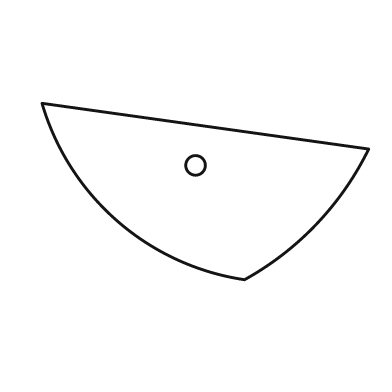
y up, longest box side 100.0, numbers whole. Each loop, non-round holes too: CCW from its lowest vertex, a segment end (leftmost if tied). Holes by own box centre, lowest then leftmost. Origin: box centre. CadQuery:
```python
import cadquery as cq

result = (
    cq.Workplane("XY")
    .moveTo(12.0, -27.0)
    .threePointArc((34.0, -10.0), (50.0, 13.0))
    .lineTo(-50.0, 27.0)
    .threePointArc((-27.0, -9.0), (12.0, -27.0))
    .close()
    .moveTo(-3.0, 8.0)
    .circle(3.0)
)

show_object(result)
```